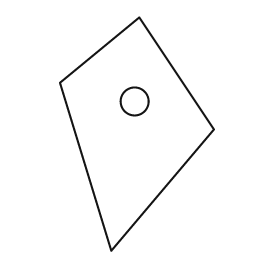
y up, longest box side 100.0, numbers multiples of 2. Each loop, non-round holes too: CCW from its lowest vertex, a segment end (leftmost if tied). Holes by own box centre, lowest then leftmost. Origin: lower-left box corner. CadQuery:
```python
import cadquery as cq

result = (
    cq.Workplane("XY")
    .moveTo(22.0, 0.0)
    .lineTo(66.0, 52.0)
    .lineTo(34.0, 100.0)
    .lineTo(0.0, 72.0)
    .close()
    .moveTo(32.0, 64.0)
    .circle(6.0)
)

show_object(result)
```